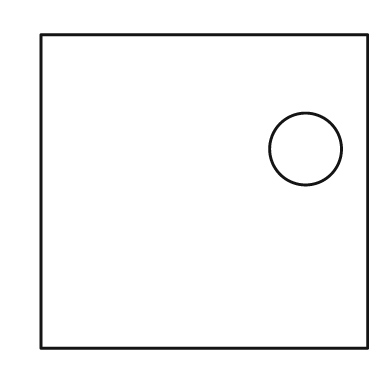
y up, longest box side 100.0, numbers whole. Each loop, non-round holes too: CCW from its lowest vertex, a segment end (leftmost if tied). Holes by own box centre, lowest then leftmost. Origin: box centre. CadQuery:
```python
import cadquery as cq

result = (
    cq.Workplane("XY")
    .moveTo(-50.0, -48.0)
    .lineTo(50.0, -48.0)
    .lineTo(50.0, 48.0)
    .lineTo(-50.0, 48.0)
    .close()
    .moveTo(31.0, 13.0)
    .circle(11.0)
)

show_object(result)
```